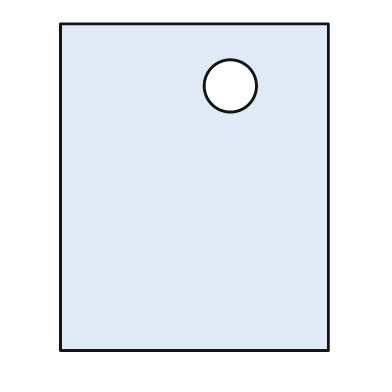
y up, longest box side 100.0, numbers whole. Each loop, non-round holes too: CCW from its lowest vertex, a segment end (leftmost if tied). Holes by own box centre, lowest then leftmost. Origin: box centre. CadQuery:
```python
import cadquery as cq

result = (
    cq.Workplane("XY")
    .moveTo(-41.0, -50.0)
    .lineTo(41.0, -50.0)
    .lineTo(41.0, 50.0)
    .lineTo(-41.0, 50.0)
    .close()
    .moveTo(11.0, 31.0)
    .circle(8.0)
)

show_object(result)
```